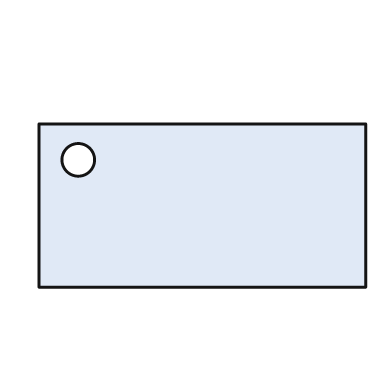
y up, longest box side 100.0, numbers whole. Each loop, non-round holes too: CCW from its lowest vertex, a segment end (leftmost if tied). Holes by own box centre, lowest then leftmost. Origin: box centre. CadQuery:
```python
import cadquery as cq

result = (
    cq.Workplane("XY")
    .moveTo(-50.0, -25.0)
    .lineTo(50.0, -25.0)
    .lineTo(50.0, 25.0)
    .lineTo(-50.0, 25.0)
    .close()
    .moveTo(-38.0, 14.0)
    .circle(5.0)
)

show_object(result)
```